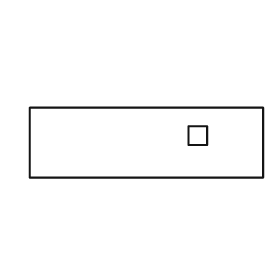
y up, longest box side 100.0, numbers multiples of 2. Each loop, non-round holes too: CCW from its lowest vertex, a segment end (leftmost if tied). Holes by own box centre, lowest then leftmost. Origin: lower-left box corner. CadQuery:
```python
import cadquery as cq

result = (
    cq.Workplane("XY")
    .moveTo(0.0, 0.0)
    .lineTo(100.0, 0.0)
    .lineTo(100.0, 30.0)
    .lineTo(0.0, 30.0)
    .close()
    .moveTo(68.0, 14.0)
    .lineTo(76.0, 14.0)
    .lineTo(76.0, 22.0)
    .lineTo(68.0, 22.0)
    .close()
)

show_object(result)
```